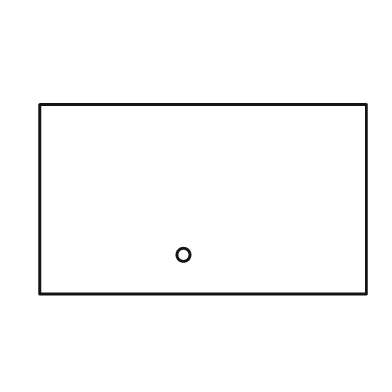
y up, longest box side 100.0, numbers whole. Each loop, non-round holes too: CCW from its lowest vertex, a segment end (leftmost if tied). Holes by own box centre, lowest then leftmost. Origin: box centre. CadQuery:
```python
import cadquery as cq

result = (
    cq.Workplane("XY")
    .moveTo(-50.0, -29.0)
    .lineTo(50.0, -29.0)
    .lineTo(50.0, 29.0)
    .lineTo(-50.0, 29.0)
    .close()
    .moveTo(-6.0, -17.0)
    .circle(2.0)
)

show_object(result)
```